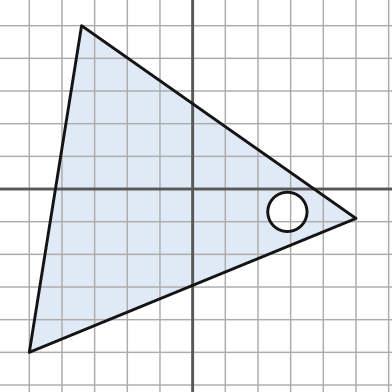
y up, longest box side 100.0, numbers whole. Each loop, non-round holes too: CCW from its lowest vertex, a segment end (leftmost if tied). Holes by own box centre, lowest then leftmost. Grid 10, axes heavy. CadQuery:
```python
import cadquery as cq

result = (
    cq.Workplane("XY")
    .moveTo(-50.0, -50.0)
    .lineTo(50.0, -9.0)
    .lineTo(-34.0, 50.0)
    .close()
    .moveTo(29.0, -7.0)
    .circle(6.0)
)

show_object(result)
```